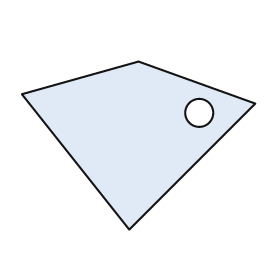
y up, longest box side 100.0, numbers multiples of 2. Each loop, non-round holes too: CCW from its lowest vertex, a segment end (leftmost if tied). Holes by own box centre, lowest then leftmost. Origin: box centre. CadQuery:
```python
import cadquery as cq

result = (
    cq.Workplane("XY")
    .moveTo(-4.0, -36.0)
    .lineTo(50.0, 18.0)
    .lineTo(0.0, 36.0)
    .lineTo(-50.0, 22.0)
    .close()
    .moveTo(26.0, 14.0)
    .circle(6.0)
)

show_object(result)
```